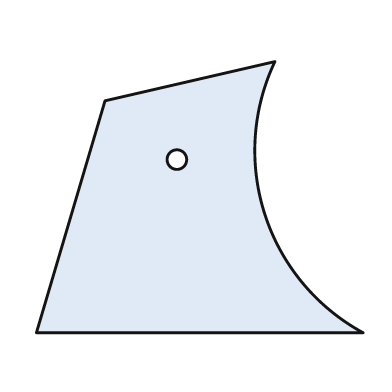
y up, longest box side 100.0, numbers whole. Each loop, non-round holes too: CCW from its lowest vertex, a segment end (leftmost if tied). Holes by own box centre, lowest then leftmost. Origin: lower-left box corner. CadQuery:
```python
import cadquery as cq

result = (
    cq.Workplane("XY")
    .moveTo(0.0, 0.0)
    .lineTo(100.0, 0.0)
    .threePointArc((70.0, 36.0), (73.0, 83.0))
    .lineTo(21.0, 71.0)
    .close()
    .moveTo(43.0, 53.0)
    .circle(3.0)
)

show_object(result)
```